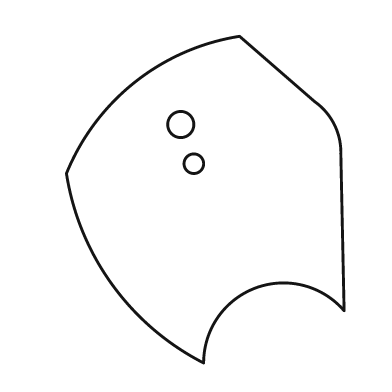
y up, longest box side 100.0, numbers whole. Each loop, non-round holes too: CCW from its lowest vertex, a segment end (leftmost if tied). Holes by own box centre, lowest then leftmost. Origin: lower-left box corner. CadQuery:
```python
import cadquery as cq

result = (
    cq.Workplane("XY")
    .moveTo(42.0, 0.0)
    .threePointArc((58.0, 23.0), (85.0, 16.0))
    .lineTo(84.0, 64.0)
    .threePointArc((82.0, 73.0), (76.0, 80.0))
    .lineTo(53.0, 100.0)
    .threePointArc((21.0, 86.0), (0.0, 58.0))
    .threePointArc((14.0, 24.0), (42.0, 0.0))
    .close()
    .moveTo(39.0, 61.0)
    .circle(3.0)
    .moveTo(35.0, 73.0)
    .circle(4.0)
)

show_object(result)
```